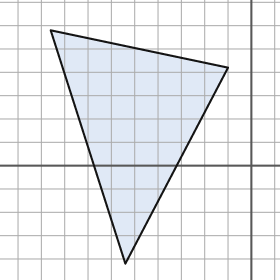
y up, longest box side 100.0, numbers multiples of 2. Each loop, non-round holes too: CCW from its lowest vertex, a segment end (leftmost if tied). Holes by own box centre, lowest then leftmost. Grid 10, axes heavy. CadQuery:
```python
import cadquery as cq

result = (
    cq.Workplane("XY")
    .moveTo(-54.0, -42.0)
    .lineTo(-10.0, 42.0)
    .lineTo(-86.0, 58.0)
    .close()
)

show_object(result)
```